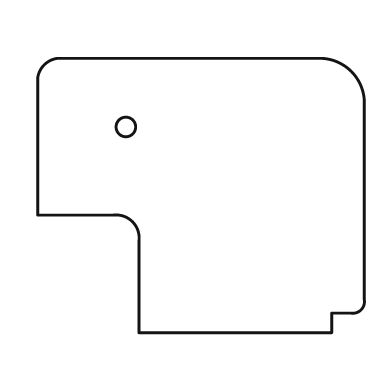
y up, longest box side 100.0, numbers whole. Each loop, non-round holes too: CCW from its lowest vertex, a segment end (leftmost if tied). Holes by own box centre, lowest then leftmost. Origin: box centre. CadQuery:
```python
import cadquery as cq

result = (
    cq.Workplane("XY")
    .moveTo(-19.0, -42.0)
    .lineTo(40.0, -42.0)
    .lineTo(40.0, -36.0)
    .lineTo(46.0, -36.0)
    .threePointArc((49.0, -35.0), (50.0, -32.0))
    .lineTo(50.0, 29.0)
    .threePointArc((46.0, 38.0), (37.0, 42.0))
    .lineTo(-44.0, 42.0)
    .threePointArc((-48.0, 40.0), (-50.0, 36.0))
    .lineTo(-50.0, -6.0)
    .lineTo(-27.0, -6.0)
    .threePointArc((-21.0, -8.0), (-19.0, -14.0))
    .close()
    .moveTo(-23.0, 21.0)
    .circle(3.0)
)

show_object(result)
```